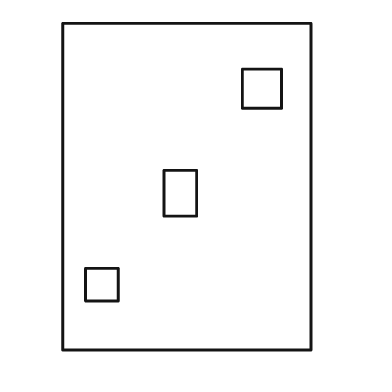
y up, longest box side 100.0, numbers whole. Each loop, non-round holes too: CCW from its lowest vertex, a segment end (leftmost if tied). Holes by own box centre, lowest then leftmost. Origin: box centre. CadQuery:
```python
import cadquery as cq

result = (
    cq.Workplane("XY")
    .moveTo(-38.0, -50.0)
    .lineTo(38.0, -50.0)
    .lineTo(38.0, 50.0)
    .lineTo(-38.0, 50.0)
    .close()
    .moveTo(-31.0, -35.0)
    .lineTo(-21.0, -35.0)
    .lineTo(-21.0, -25.0)
    .lineTo(-31.0, -25.0)
    .close()
    .moveTo(-7.0, -9.0)
    .lineTo(3.0, -9.0)
    .lineTo(3.0, 5.0)
    .lineTo(-7.0, 5.0)
    .close()
    .moveTo(17.0, 24.0)
    .lineTo(29.0, 24.0)
    .lineTo(29.0, 36.0)
    .lineTo(17.0, 36.0)
    .close()
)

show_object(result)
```